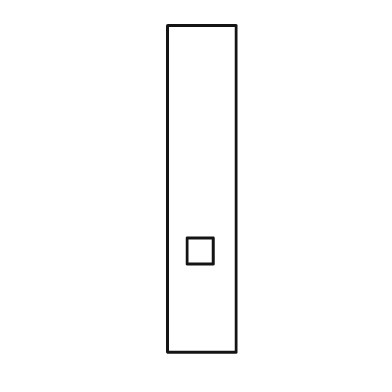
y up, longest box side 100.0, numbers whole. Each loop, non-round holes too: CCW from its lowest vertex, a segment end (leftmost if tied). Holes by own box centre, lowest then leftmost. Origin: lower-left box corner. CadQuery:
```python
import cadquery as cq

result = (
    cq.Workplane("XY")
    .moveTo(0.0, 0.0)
    .lineTo(21.0, 0.0)
    .lineTo(21.0, 100.0)
    .lineTo(0.0, 100.0)
    .close()
    .moveTo(6.0, 27.0)
    .lineTo(14.0, 27.0)
    .lineTo(14.0, 35.0)
    .lineTo(6.0, 35.0)
    .close()
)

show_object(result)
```